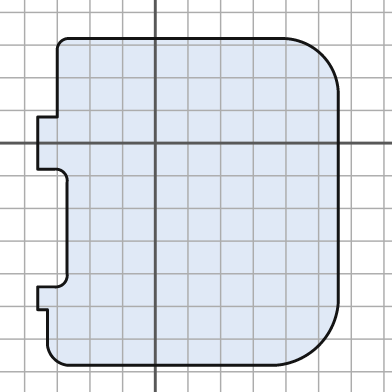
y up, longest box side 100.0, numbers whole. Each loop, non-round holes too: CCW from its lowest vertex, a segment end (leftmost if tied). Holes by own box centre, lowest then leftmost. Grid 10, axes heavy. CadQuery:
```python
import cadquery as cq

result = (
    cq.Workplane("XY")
    .moveTo(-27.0, -68.0)
    .lineTo(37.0, -68.0)
    .threePointArc((50.0, -62.0), (56.0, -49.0))
    .lineTo(56.0, 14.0)
    .threePointArc((51.0, 27.0), (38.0, 32.0))
    .lineTo(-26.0, 32.0)
    .threePointArc((-29.0, 31.0), (-30.0, 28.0))
    .lineTo(-30.0, 8.0)
    .lineTo(-36.0, 8.0)
    .lineTo(-36.0, -8.0)
    .lineTo(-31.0, -8.0)
    .threePointArc((-28.0, -9.0), (-27.0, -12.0))
    .lineTo(-27.0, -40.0)
    .threePointArc((-28.0, -43.0), (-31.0, -44.0))
    .lineTo(-36.0, -44.0)
    .lineTo(-36.0, -51.0)
    .lineTo(-33.0, -51.0)
    .lineTo(-33.0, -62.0)
    .threePointArc((-31.0, -66.0), (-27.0, -68.0))
    .close()
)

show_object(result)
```